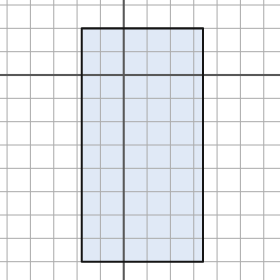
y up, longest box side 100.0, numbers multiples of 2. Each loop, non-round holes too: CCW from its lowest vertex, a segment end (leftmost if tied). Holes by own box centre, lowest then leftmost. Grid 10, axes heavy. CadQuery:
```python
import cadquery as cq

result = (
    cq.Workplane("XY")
    .moveTo(-18.0, -80.0)
    .lineTo(34.0, -80.0)
    .lineTo(34.0, 20.0)
    .lineTo(-18.0, 20.0)
    .close()
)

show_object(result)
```